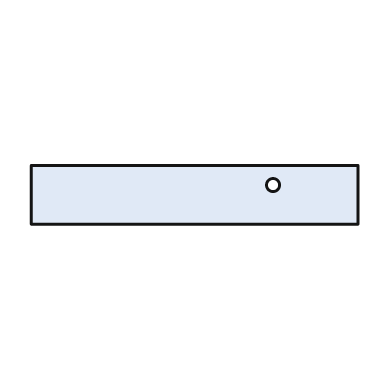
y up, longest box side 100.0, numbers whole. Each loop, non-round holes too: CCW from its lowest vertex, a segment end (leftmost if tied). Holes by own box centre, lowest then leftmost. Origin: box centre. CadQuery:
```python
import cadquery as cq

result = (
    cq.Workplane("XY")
    .moveTo(-50.0, -9.0)
    .lineTo(50.0, -9.0)
    .lineTo(50.0, 9.0)
    .lineTo(-50.0, 9.0)
    .close()
    .moveTo(24.0, 3.0)
    .circle(2.0)
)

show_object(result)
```